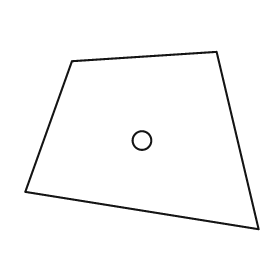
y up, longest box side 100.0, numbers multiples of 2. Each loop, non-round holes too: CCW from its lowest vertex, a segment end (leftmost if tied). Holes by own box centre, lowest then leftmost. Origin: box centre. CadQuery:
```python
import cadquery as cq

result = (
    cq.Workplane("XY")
    .moveTo(50.0, -38.0)
    .lineTo(32.0, 38.0)
    .lineTo(-30.0, 34.0)
    .lineTo(-50.0, -22.0)
    .close()
    .moveTo(0.0, 0.0)
    .circle(4.0)
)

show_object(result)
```